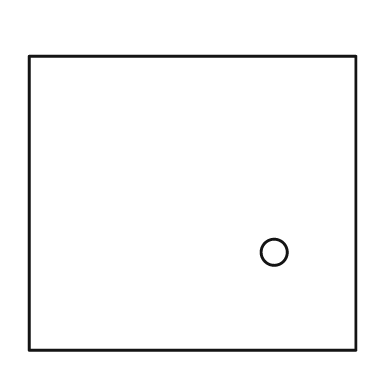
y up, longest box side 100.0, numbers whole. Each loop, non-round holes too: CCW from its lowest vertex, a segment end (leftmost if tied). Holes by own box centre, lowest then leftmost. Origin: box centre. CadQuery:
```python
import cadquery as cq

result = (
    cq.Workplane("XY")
    .moveTo(-50.0, -45.0)
    .lineTo(50.0, -45.0)
    .lineTo(50.0, 45.0)
    .lineTo(-50.0, 45.0)
    .close()
    .moveTo(25.0, -15.0)
    .circle(4.0)
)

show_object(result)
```